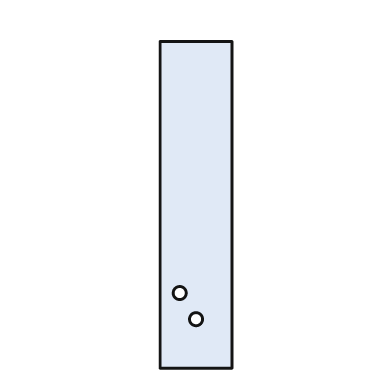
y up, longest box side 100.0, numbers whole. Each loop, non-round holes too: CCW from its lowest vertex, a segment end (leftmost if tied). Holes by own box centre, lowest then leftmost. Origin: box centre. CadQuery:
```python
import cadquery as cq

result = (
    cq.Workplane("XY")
    .moveTo(-11.0, -50.0)
    .lineTo(11.0, -50.0)
    .lineTo(11.0, 50.0)
    .lineTo(-11.0, 50.0)
    .close()
    .moveTo(0.0, -35.0)
    .circle(2.0)
    .moveTo(-5.0, -27.0)
    .circle(2.0)
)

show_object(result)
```